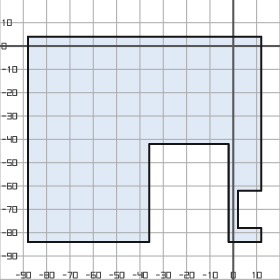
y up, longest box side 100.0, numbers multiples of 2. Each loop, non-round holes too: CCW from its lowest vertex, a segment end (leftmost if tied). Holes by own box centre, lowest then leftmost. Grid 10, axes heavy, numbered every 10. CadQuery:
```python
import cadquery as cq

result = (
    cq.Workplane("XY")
    .moveTo(-88.0, -84.0)
    .lineTo(-36.0, -84.0)
    .lineTo(-36.0, -42.0)
    .lineTo(-2.0, -42.0)
    .lineTo(-2.0, -84.0)
    .lineTo(12.0, -84.0)
    .lineTo(12.0, -78.0)
    .lineTo(2.0, -78.0)
    .lineTo(2.0, -62.0)
    .lineTo(12.0, -62.0)
    .lineTo(12.0, 4.0)
    .lineTo(-88.0, 4.0)
    .close()
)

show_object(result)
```